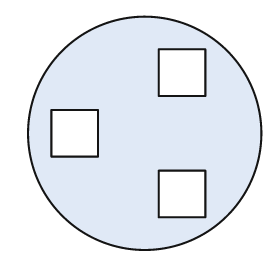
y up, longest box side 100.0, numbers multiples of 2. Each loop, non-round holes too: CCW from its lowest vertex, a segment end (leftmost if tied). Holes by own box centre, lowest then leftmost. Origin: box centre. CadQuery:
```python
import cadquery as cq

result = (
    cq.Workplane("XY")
    .moveTo(0.0, 0.0)
    .circle(50.0)
    .moveTo(6.0, -36.0)
    .lineTo(26.0, -36.0)
    .lineTo(26.0, -16.0)
    .lineTo(6.0, -16.0)
    .close()
    .moveTo(-40.0, -10.0)
    .lineTo(-20.0, -10.0)
    .lineTo(-20.0, 10.0)
    .lineTo(-40.0, 10.0)
    .close()
    .moveTo(6.0, 16.0)
    .lineTo(26.0, 16.0)
    .lineTo(26.0, 36.0)
    .lineTo(6.0, 36.0)
    .close()
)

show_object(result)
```